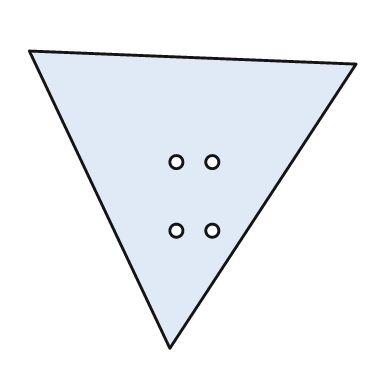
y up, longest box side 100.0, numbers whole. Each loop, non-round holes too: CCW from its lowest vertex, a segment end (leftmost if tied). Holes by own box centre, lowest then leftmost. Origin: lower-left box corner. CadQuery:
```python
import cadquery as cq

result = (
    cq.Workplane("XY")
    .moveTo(43.0, 0.0)
    .lineTo(100.0, 87.0)
    .lineTo(0.0, 91.0)
    .close()
    .moveTo(45.0, 36.0)
    .circle(2.0)
    .moveTo(56.0, 36.0)
    .circle(2.0)
    .moveTo(45.0, 57.0)
    .circle(2.0)
    .moveTo(56.0, 57.0)
    .circle(2.0)
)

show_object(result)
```